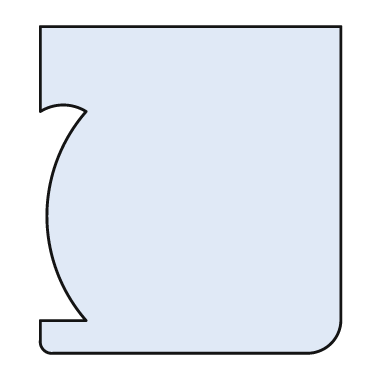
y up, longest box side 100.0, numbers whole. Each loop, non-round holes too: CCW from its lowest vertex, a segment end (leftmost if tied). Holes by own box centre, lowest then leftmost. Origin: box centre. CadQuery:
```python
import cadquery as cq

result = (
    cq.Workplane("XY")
    .moveTo(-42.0, -50.0)
    .lineTo(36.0, -50.0)
    .threePointArc((43.0, -47.0), (46.0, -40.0))
    .lineTo(46.0, 50.0)
    .lineTo(-46.0, 50.0)
    .lineTo(-46.0, 24.0)
    .threePointArc((-39.0, 26.0), (-32.0, 24.0))
    .threePointArc((-44.0, -8.0), (-32.0, -40.0))
    .lineTo(-46.0, -40.0)
    .lineTo(-46.0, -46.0)
    .threePointArc((-45.0, -49.0), (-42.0, -50.0))
    .close()
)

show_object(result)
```